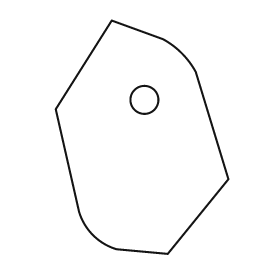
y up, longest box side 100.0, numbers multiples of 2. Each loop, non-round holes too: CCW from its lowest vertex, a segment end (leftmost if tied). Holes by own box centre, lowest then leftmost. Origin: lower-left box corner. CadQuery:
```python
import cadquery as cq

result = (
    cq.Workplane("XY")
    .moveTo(48.0, 0.0)
    .lineTo(74.0, 32.0)
    .lineTo(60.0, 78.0)
    .threePointArc((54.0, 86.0), (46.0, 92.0))
    .lineTo(24.0, 100.0)
    .lineTo(0.0, 62.0)
    .lineTo(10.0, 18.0)
    .threePointArc((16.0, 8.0), (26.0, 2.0))
    .close()
    .moveTo(38.0, 66.0)
    .circle(6.0)
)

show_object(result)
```